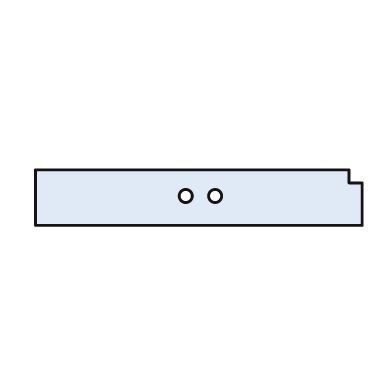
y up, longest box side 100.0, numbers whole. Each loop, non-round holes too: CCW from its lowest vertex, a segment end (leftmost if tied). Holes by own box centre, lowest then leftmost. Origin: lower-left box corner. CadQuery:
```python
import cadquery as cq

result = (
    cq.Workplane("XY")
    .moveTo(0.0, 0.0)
    .lineTo(100.0, 0.0)
    .lineTo(100.0, 13.0)
    .lineTo(96.0, 13.0)
    .lineTo(96.0, 17.0)
    .lineTo(0.0, 17.0)
    .close()
    .moveTo(46.0, 9.0)
    .circle(2.0)
    .moveTo(55.0, 9.0)
    .circle(2.0)
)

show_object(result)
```